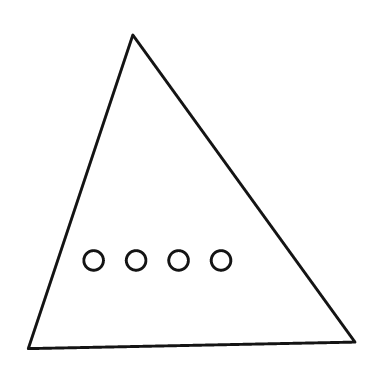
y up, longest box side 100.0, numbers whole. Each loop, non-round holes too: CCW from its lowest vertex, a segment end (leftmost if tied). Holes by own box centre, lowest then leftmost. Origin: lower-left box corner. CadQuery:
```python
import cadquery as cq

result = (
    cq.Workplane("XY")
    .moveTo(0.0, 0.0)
    .lineTo(100.0, 2.0)
    .lineTo(32.0, 96.0)
    .close()
    .moveTo(20.0, 27.0)
    .circle(3.0)
    .moveTo(33.0, 27.0)
    .circle(3.0)
    .moveTo(46.0, 27.0)
    .circle(3.0)
    .moveTo(59.0, 27.0)
    .circle(3.0)
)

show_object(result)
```